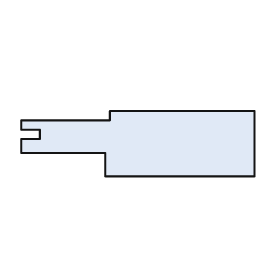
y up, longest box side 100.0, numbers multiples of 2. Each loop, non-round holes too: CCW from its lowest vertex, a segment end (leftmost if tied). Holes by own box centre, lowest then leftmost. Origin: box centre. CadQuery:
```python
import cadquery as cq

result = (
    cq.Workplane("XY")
    .moveTo(-14.0, -14.0)
    .lineTo(50.0, -14.0)
    .lineTo(50.0, 14.0)
    .lineTo(-12.0, 14.0)
    .lineTo(-12.0, 10.0)
    .lineTo(-50.0, 10.0)
    .lineTo(-50.0, 6.0)
    .lineTo(-42.0, 6.0)
    .lineTo(-42.0, 2.0)
    .lineTo(-50.0, 2.0)
    .lineTo(-50.0, -4.0)
    .lineTo(-14.0, -4.0)
    .close()
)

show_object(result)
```